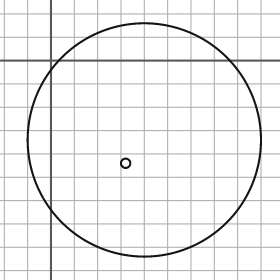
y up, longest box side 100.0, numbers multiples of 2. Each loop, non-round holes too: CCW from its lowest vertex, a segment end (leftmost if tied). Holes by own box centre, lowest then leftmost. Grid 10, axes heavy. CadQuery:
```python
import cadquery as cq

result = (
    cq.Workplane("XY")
    .moveTo(40.0, -34.0)
    .circle(50.0)
    .moveTo(32.0, -44.0)
    .circle(2.0)
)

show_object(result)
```